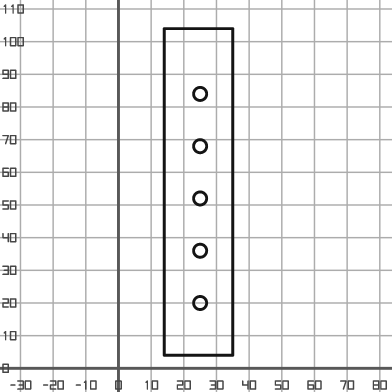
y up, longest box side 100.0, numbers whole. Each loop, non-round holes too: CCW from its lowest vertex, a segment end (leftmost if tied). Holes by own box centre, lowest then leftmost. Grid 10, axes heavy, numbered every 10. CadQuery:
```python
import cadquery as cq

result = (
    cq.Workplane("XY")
    .moveTo(14.0, 4.0)
    .lineTo(35.0, 4.0)
    .lineTo(35.0, 104.0)
    .lineTo(14.0, 104.0)
    .close()
    .moveTo(25.0, 20.0)
    .circle(2.0)
    .moveTo(25.0, 36.0)
    .circle(2.0)
    .moveTo(25.0, 52.0)
    .circle(2.0)
    .moveTo(25.0, 68.0)
    .circle(2.0)
    .moveTo(25.0, 84.0)
    .circle(2.0)
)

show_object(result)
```